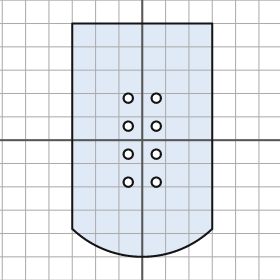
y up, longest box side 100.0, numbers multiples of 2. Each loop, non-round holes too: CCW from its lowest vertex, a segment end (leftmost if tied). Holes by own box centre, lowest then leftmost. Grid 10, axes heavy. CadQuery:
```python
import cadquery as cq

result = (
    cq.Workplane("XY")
    .moveTo(-30.0, -38.0)
    .threePointArc((0.0, -50.0), (30.0, -38.0))
    .lineTo(30.0, 50.0)
    .lineTo(-30.0, 50.0)
    .close()
    .moveTo(-6.0, -18.0)
    .circle(2.0)
    .moveTo(6.0, -18.0)
    .circle(2.0)
    .moveTo(-6.0, -6.0)
    .circle(2.0)
    .moveTo(6.0, -6.0)
    .circle(2.0)
    .moveTo(-6.0, 6.0)
    .circle(2.0)
    .moveTo(6.0, 6.0)
    .circle(2.0)
    .moveTo(-6.0, 18.0)
    .circle(2.0)
    .moveTo(6.0, 18.0)
    .circle(2.0)
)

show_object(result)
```